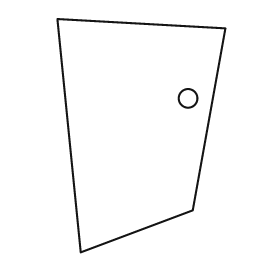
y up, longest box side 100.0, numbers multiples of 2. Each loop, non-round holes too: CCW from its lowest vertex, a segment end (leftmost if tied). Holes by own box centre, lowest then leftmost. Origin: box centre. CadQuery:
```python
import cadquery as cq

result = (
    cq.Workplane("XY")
    .moveTo(-26.0, -50.0)
    .lineTo(22.0, -32.0)
    .lineTo(36.0, 46.0)
    .lineTo(-36.0, 50.0)
    .close()
    .moveTo(20.0, 16.0)
    .circle(4.0)
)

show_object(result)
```